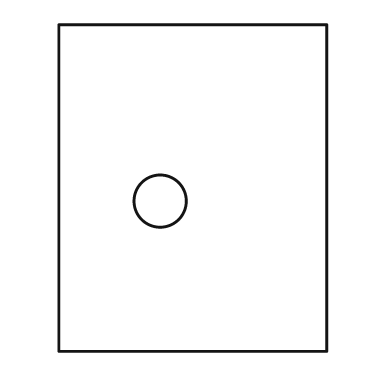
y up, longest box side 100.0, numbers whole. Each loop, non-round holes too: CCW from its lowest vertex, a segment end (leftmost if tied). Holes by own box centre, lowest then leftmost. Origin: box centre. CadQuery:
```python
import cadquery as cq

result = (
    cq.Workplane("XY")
    .moveTo(-41.0, -50.0)
    .lineTo(41.0, -50.0)
    .lineTo(41.0, 50.0)
    .lineTo(-41.0, 50.0)
    .close()
    .moveTo(-10.0, -4.0)
    .circle(8.0)
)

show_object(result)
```